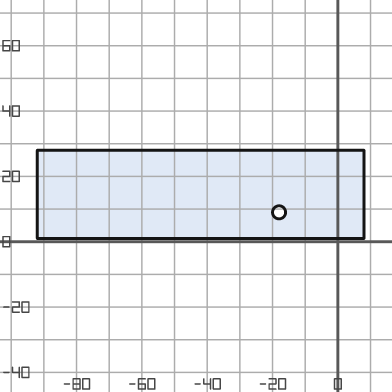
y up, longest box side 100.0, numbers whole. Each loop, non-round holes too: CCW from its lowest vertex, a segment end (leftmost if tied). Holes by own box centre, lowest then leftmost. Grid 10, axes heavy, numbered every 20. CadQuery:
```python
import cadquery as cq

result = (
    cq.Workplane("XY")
    .moveTo(-92.0, 1.0)
    .lineTo(8.0, 1.0)
    .lineTo(8.0, 28.0)
    .lineTo(-92.0, 28.0)
    .close()
    .moveTo(-18.0, 9.0)
    .circle(2.0)
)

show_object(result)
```